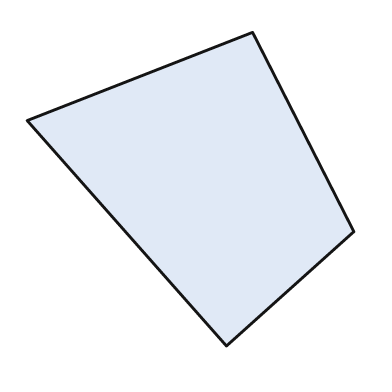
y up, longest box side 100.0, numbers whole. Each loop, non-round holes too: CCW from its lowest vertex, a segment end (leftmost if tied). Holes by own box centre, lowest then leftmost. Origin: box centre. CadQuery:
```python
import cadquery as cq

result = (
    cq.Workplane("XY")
    .moveTo(11.0, -48.0)
    .lineTo(50.0, -13.0)
    .lineTo(19.0, 48.0)
    .lineTo(-50.0, 21.0)
    .close()
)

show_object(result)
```